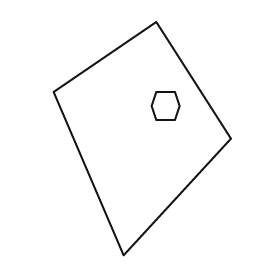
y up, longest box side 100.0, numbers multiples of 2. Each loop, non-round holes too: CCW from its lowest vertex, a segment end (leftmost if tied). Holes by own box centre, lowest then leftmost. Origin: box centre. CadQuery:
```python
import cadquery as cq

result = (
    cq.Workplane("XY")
    .moveTo(-8.0, -50.0)
    .lineTo(38.0, 0.0)
    .lineTo(6.0, 50.0)
    .lineTo(-38.0, 20.0)
    .close()
    .moveTo(6.0, 8.0)
    .lineTo(14.0, 8.0)
    .lineTo(16.0, 14.0)
    .lineTo(14.0, 20.0)
    .lineTo(6.0, 20.0)
    .lineTo(4.0, 14.0)
    .close()
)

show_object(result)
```